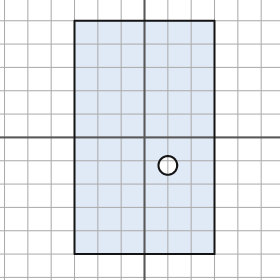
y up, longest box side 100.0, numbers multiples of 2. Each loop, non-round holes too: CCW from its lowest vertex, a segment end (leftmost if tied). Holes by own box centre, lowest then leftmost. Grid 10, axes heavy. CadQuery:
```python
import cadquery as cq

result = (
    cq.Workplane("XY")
    .moveTo(-30.0, -50.0)
    .lineTo(30.0, -50.0)
    .lineTo(30.0, 50.0)
    .lineTo(-30.0, 50.0)
    .close()
    .moveTo(10.0, -12.0)
    .circle(4.0)
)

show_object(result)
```